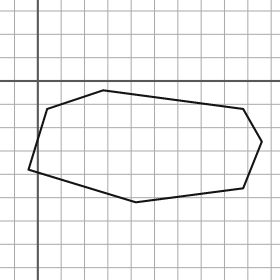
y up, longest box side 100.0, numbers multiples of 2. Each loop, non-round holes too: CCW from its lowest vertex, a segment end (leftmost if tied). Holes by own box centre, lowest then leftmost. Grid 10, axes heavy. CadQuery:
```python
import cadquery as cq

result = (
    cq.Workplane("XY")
    .moveTo(42.0, -52.0)
    .lineTo(88.0, -46.0)
    .lineTo(96.0, -26.0)
    .lineTo(88.0, -12.0)
    .lineTo(28.0, -4.0)
    .lineTo(4.0, -12.0)
    .lineTo(-4.0, -38.0)
    .close()
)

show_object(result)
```